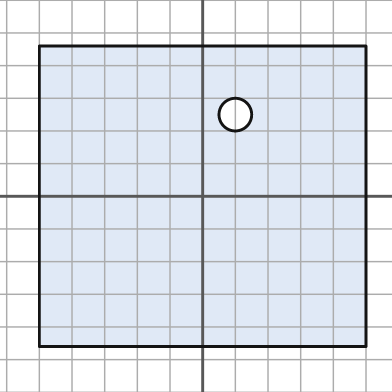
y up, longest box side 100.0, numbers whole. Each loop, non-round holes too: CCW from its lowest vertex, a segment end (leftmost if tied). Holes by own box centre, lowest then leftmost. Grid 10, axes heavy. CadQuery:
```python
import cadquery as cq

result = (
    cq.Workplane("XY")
    .moveTo(-50.0, -46.0)
    .lineTo(50.0, -46.0)
    .lineTo(50.0, 46.0)
    .lineTo(-50.0, 46.0)
    .close()
    .moveTo(10.0, 25.0)
    .circle(5.0)
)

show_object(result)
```